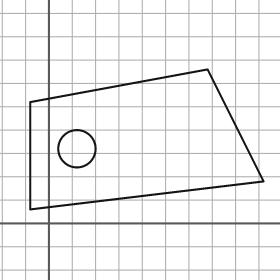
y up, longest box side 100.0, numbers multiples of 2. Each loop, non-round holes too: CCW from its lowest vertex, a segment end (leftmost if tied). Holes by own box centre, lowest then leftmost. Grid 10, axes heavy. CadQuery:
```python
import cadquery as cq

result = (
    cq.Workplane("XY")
    .moveTo(-8.0, 6.0)
    .lineTo(92.0, 18.0)
    .lineTo(68.0, 66.0)
    .lineTo(-8.0, 52.0)
    .close()
    .moveTo(12.0, 32.0)
    .circle(8.0)
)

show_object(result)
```